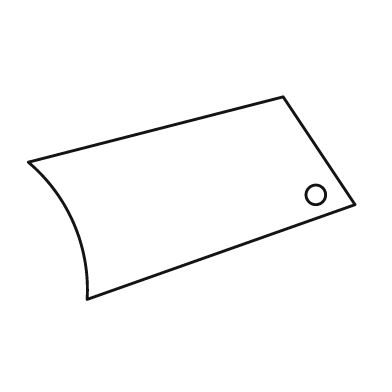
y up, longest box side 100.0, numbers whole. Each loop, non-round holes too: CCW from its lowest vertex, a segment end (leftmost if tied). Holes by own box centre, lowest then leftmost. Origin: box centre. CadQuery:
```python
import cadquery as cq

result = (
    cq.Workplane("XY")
    .moveTo(-32.0, -31.0)
    .lineTo(50.0, -2.0)
    .lineTo(28.0, 31.0)
    .lineTo(-50.0, 11.0)
    .threePointArc((-36.0, -8.0), (-32.0, -31.0))
    .close()
    .moveTo(38.0, 1.0)
    .circle(3.0)
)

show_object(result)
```